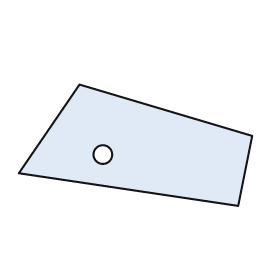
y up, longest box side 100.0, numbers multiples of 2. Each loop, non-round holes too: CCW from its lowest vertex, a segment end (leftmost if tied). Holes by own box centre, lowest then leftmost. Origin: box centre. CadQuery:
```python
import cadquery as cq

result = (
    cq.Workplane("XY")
    .moveTo(44.0, -26.0)
    .lineTo(50.0, 4.0)
    .lineTo(-24.0, 26.0)
    .lineTo(-50.0, -12.0)
    .close()
    .moveTo(-14.0, -4.0)
    .circle(4.0)
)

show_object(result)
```